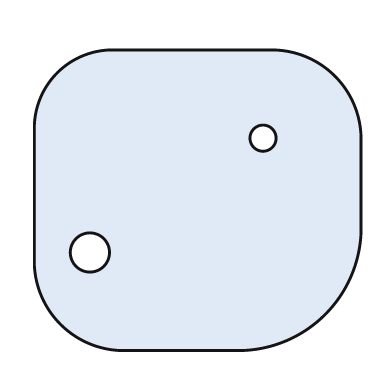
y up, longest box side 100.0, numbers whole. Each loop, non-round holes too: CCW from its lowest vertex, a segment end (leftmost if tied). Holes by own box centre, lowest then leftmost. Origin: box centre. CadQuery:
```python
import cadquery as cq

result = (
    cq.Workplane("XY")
    .moveTo(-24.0, -46.0)
    .lineTo(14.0, -46.0)
    .threePointArc((39.0, -35.0), (50.0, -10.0))
    .lineTo(50.0, 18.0)
    .threePointArc((42.0, 38.0), (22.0, 46.0))
    .lineTo(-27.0, 46.0)
    .threePointArc((-43.0, 39.0), (-50.0, 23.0))
    .lineTo(-50.0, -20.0)
    .threePointArc((-42.0, -38.0), (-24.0, -46.0))
    .close()
    .moveTo(-33.0, -16.0)
    .circle(6.0)
    .moveTo(20.0, 19.0)
    .circle(4.0)
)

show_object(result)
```